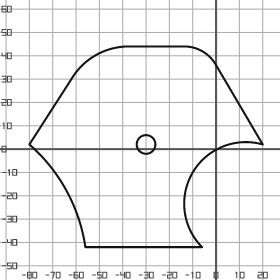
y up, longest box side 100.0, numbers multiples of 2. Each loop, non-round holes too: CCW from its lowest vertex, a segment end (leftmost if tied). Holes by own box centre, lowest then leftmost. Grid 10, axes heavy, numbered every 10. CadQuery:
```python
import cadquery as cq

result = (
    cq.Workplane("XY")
    .moveTo(-56.0, -42.0)
    .lineTo(-6.0, -42.0)
    .threePointArc((-10.0, -10.0), (20.0, 2.0))
    .lineTo(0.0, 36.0)
    .threePointArc((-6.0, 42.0), (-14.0, 44.0))
    .lineTo(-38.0, 44.0)
    .threePointArc((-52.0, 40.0), (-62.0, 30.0))
    .lineTo(-80.0, 2.0)
    .threePointArc((-64.0, -18.0), (-56.0, -42.0))
    .close()
    .moveTo(-30.0, 2.0)
    .circle(4.0)
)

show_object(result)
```